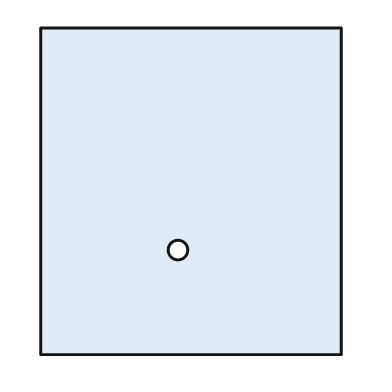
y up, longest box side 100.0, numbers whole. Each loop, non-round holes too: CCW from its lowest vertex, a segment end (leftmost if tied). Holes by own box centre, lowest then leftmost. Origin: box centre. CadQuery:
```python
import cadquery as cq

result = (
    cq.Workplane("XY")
    .moveTo(-46.0, -50.0)
    .lineTo(46.0, -50.0)
    .lineTo(46.0, 50.0)
    .lineTo(-46.0, 50.0)
    .close()
    .moveTo(-4.0, -18.0)
    .circle(3.0)
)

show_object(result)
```